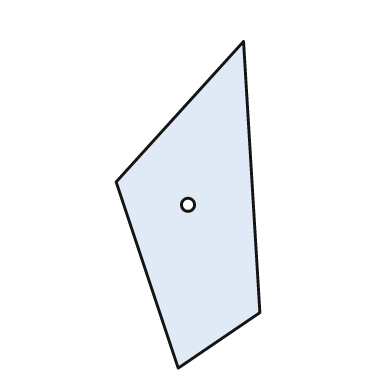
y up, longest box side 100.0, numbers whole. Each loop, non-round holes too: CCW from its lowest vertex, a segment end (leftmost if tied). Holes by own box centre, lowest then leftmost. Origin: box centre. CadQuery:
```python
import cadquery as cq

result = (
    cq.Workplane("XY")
    .moveTo(-3.0, -50.0)
    .lineTo(22.0, -33.0)
    .lineTo(17.0, 50.0)
    .lineTo(-22.0, 7.0)
    .close()
    .moveTo(0.0, 0.0)
    .circle(2.0)
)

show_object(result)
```